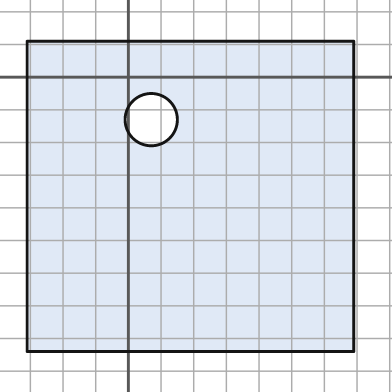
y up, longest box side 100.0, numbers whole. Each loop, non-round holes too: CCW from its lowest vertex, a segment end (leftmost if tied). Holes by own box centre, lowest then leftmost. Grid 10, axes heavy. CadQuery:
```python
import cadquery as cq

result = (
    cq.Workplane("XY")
    .moveTo(-31.0, -84.0)
    .lineTo(69.0, -84.0)
    .lineTo(69.0, 11.0)
    .lineTo(-31.0, 11.0)
    .close()
    .moveTo(7.0, -13.0)
    .circle(8.0)
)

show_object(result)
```